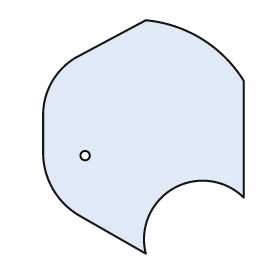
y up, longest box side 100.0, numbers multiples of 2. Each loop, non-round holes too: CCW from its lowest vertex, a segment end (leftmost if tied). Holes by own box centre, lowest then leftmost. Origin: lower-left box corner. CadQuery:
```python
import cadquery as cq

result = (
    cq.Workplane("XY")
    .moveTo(44.0, 0.0)
    .threePointArc((56.0, 28.0), (86.0, 24.0))
    .lineTo(86.0, 74.0)
    .threePointArc((68.0, 92.0), (44.0, 100.0))
    .lineTo(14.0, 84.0)
    .threePointArc((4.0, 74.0), (0.0, 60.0))
    .lineTo(0.0, 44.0)
    .threePointArc((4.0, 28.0), (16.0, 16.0))
    .close()
    .moveTo(18.0, 42.0)
    .circle(2.0)
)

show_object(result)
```